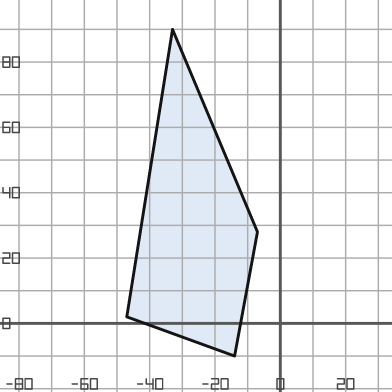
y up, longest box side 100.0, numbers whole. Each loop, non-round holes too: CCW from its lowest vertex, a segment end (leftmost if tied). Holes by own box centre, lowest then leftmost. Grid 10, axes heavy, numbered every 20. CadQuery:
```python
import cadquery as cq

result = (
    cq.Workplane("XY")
    .moveTo(-14.0, -10.0)
    .lineTo(-7.0, 28.0)
    .lineTo(-33.0, 90.0)
    .lineTo(-47.0, 2.0)
    .close()
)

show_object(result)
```